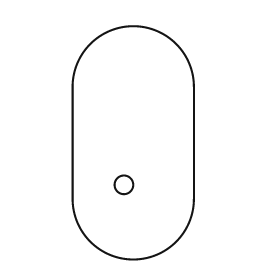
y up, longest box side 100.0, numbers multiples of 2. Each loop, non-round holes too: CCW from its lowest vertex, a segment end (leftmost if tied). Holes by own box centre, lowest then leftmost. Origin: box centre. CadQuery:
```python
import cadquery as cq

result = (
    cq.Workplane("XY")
    .moveTo(-26.0, -24.0)
    .threePointArc((0.0, -50.0), (26.0, -24.0))
    .lineTo(26.0, 24.0)
    .threePointArc((0.0, 50.0), (-26.0, 24.0))
    .close()
    .moveTo(-4.0, -18.0)
    .circle(4.0)
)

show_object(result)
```